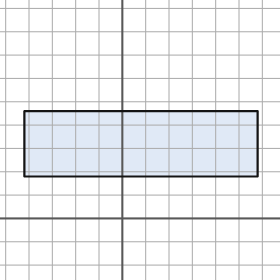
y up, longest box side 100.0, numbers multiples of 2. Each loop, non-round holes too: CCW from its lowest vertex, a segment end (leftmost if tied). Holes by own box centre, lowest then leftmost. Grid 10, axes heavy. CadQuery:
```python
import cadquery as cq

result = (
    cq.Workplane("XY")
    .moveTo(-42.0, 18.0)
    .lineTo(58.0, 18.0)
    .lineTo(58.0, 46.0)
    .lineTo(-42.0, 46.0)
    .close()
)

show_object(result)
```